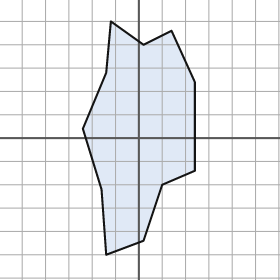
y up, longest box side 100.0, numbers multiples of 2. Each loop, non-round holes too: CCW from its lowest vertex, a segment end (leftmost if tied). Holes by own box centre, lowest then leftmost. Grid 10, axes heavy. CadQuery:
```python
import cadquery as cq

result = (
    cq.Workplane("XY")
    .moveTo(-14.0, -50.0)
    .lineTo(2.0, -44.0)
    .lineTo(10.0, -20.0)
    .lineTo(24.0, -14.0)
    .lineTo(24.0, 24.0)
    .lineTo(14.0, 46.0)
    .lineTo(2.0, 40.0)
    .lineTo(-12.0, 50.0)
    .lineTo(-14.0, 28.0)
    .lineTo(-24.0, 4.0)
    .lineTo(-16.0, -22.0)
    .close()
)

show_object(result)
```